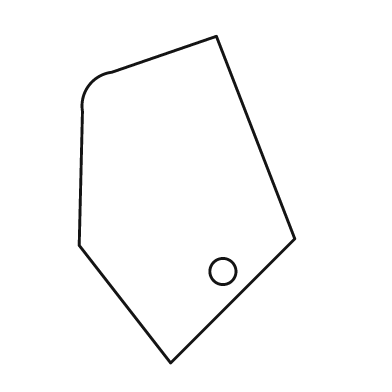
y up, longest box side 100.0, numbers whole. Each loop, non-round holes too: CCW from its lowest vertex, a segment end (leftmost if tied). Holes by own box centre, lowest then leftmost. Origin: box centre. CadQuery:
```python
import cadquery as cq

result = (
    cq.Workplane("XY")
    .moveTo(-5.0, -50.0)
    .lineTo(33.0, -12.0)
    .lineTo(9.0, 50.0)
    .lineTo(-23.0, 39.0)
    .threePointArc((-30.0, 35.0), (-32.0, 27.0))
    .lineTo(-33.0, -14.0)
    .close()
    .moveTo(11.0, -22.0)
    .circle(4.0)
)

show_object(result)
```